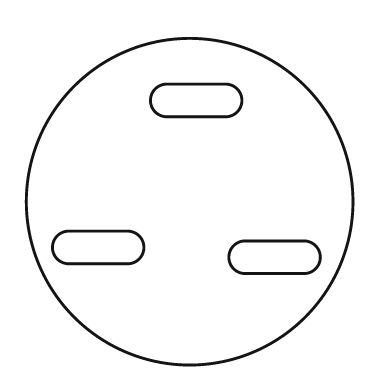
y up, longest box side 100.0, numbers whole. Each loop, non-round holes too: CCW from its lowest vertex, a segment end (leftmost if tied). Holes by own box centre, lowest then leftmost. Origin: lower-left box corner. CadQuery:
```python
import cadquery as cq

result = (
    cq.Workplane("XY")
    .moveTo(50.0, 50.0)
    .circle(50.0)
    .moveTo(67.0, 28.0)
    .lineTo(85.0, 28.0)
    .threePointArc((90.0, 33.0), (85.0, 38.0))
    .lineTo(67.0, 38.0)
    .threePointArc((62.0, 33.0), (67.0, 28.0))
    .close()
    .moveTo(13.0, 31.0)
    .lineTo(31.0, 31.0)
    .threePointArc((36.0, 36.0), (31.0, 41.0))
    .lineTo(13.0, 41.0)
    .threePointArc((8.0, 36.0), (13.0, 31.0))
    .close()
    .moveTo(43.0, 76.0)
    .lineTo(61.0, 76.0)
    .threePointArc((66.0, 81.0), (61.0, 86.0))
    .lineTo(43.0, 86.0)
    .threePointArc((38.0, 81.0), (43.0, 76.0))
    .close()
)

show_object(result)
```